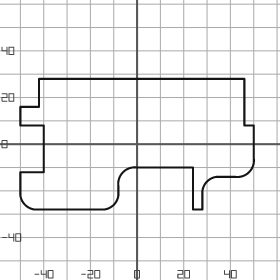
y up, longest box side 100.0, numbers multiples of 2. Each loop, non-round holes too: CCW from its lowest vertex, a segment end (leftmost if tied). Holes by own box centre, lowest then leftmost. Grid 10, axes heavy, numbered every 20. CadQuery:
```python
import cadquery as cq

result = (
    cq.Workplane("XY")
    .moveTo(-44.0, -28.0)
    .lineTo(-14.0, -28.0)
    .threePointArc((-10.0, -26.0), (-8.0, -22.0))
    .lineTo(-8.0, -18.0)
    .threePointArc((-6.0, -12.0), (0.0, -10.0))
    .lineTo(24.0, -10.0)
    .lineTo(24.0, -28.0)
    .lineTo(28.0, -28.0)
    .lineTo(28.0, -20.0)
    .threePointArc((30.0, -16.0), (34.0, -14.0))
    .lineTo(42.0, -14.0)
    .threePointArc((48.0, -12.0), (50.0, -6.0))
    .lineTo(50.0, 8.0)
    .lineTo(46.0, 8.0)
    .lineTo(46.0, 28.0)
    .lineTo(-42.0, 28.0)
    .lineTo(-42.0, 16.0)
    .lineTo(-50.0, 16.0)
    .lineTo(-50.0, 8.0)
    .lineTo(-40.0, 8.0)
    .lineTo(-40.0, -12.0)
    .lineTo(-50.0, -12.0)
    .lineTo(-50.0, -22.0)
    .threePointArc((-48.0, -26.0), (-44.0, -28.0))
    .close()
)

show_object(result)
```